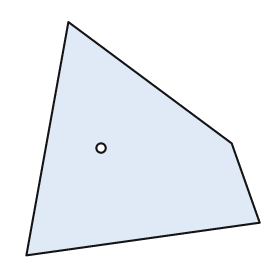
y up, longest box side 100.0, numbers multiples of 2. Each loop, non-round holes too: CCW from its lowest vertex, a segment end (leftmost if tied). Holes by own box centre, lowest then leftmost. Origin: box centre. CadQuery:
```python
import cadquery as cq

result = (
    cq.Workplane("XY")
    .moveTo(-50.0, -50.0)
    .lineTo(50.0, -36.0)
    .lineTo(38.0, -2.0)
    .lineTo(-32.0, 50.0)
    .close()
    .moveTo(-18.0, -4.0)
    .circle(2.0)
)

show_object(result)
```